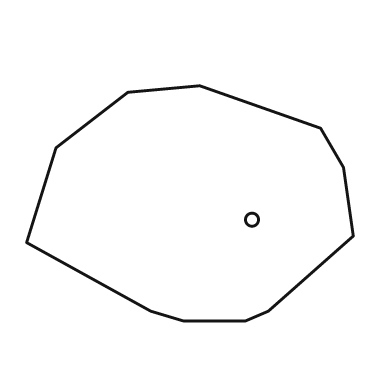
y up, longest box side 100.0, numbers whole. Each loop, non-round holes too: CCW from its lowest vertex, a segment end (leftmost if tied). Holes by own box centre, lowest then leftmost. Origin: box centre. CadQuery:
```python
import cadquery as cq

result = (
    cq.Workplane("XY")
    .moveTo(-2.0, -36.0)
    .lineTo(17.0, -36.0)
    .lineTo(24.0, -33.0)
    .lineTo(50.0, -10.0)
    .lineTo(47.0, 11.0)
    .lineTo(40.0, 23.0)
    .lineTo(3.0, 36.0)
    .lineTo(-19.0, 34.0)
    .lineTo(-41.0, 17.0)
    .lineTo(-50.0, -12.0)
    .lineTo(-12.0, -33.0)
    .close()
    .moveTo(19.0, -5.0)
    .circle(2.0)
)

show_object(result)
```